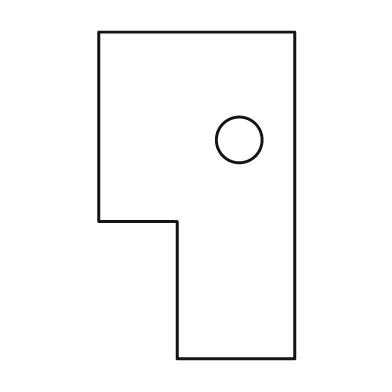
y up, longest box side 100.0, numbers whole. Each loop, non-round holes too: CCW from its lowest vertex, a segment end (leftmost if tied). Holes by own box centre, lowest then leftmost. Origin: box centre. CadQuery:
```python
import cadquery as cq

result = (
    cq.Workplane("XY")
    .moveTo(-6.0, -50.0)
    .lineTo(30.0, -50.0)
    .lineTo(30.0, 50.0)
    .lineTo(-30.0, 50.0)
    .lineTo(-30.0, -8.0)
    .lineTo(-6.0, -8.0)
    .close()
    .moveTo(13.0, 17.0)
    .circle(7.0)
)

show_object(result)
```